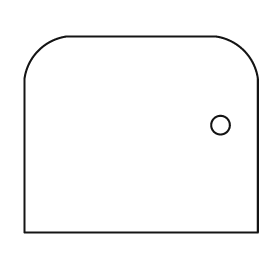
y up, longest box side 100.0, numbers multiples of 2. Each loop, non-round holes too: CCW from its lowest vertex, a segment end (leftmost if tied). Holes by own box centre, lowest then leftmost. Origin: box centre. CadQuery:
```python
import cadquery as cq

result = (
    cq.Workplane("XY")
    .moveTo(-50.0, -42.0)
    .lineTo(50.0, -42.0)
    .lineTo(50.0, 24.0)
    .threePointArc((44.0, 36.0), (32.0, 42.0))
    .lineTo(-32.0, 42.0)
    .threePointArc((-44.0, 36.0), (-50.0, 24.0))
    .close()
    .moveTo(34.0, 4.0)
    .circle(4.0)
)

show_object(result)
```